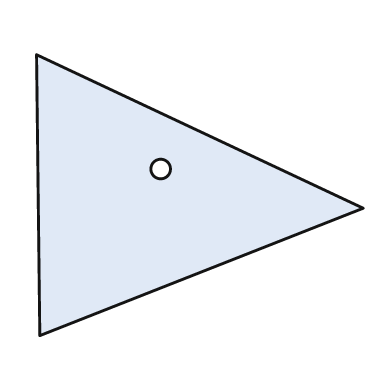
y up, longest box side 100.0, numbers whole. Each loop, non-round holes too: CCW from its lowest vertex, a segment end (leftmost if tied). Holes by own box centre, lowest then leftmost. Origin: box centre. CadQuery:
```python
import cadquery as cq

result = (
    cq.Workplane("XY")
    .moveTo(-49.0, -43.0)
    .lineTo(50.0, -4.0)
    .lineTo(-50.0, 43.0)
    .close()
    .moveTo(-12.0, 8.0)
    .circle(3.0)
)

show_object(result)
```